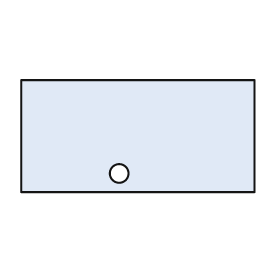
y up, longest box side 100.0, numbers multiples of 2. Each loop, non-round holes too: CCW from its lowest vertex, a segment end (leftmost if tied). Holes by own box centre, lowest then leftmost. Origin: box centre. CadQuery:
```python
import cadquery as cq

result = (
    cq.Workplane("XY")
    .moveTo(-50.0, -24.0)
    .lineTo(50.0, -24.0)
    .lineTo(50.0, 24.0)
    .lineTo(-50.0, 24.0)
    .close()
    .moveTo(-8.0, -16.0)
    .circle(4.0)
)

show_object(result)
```